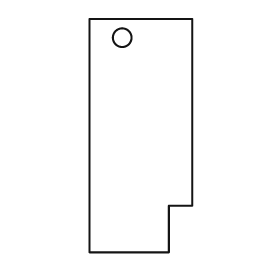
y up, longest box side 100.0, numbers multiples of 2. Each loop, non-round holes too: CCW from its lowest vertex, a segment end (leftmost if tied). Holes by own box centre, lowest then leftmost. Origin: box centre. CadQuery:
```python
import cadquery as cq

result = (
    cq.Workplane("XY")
    .moveTo(-22.0, -50.0)
    .lineTo(12.0, -50.0)
    .lineTo(12.0, -30.0)
    .lineTo(22.0, -30.0)
    .lineTo(22.0, 50.0)
    .lineTo(-22.0, 50.0)
    .close()
    .moveTo(-8.0, 42.0)
    .circle(4.0)
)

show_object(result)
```